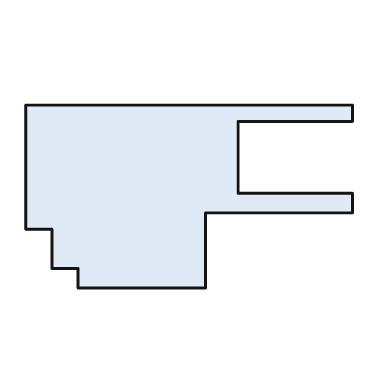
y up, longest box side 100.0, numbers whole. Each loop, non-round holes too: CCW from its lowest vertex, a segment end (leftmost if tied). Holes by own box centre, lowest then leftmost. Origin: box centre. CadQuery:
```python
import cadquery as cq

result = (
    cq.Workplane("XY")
    .moveTo(-34.0, -28.0)
    .lineTo(5.0, -28.0)
    .lineTo(5.0, -5.0)
    .lineTo(50.0, -5.0)
    .lineTo(50.0, 1.0)
    .lineTo(15.0, 1.0)
    .lineTo(15.0, 23.0)
    .lineTo(50.0, 23.0)
    .lineTo(50.0, 28.0)
    .lineTo(-50.0, 28.0)
    .lineTo(-50.0, -10.0)
    .lineTo(-42.0, -10.0)
    .lineTo(-42.0, -22.0)
    .lineTo(-34.0, -22.0)
    .close()
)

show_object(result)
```